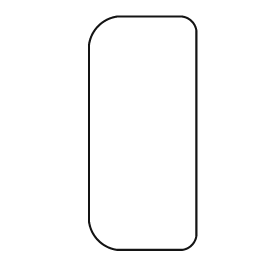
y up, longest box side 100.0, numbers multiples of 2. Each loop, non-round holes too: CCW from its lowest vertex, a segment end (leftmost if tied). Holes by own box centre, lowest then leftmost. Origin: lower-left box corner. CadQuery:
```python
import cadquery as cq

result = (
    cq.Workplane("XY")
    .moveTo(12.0, 0.0)
    .lineTo(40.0, 0.0)
    .threePointArc((44.0, 2.0), (46.0, 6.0))
    .lineTo(46.0, 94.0)
    .threePointArc((44.0, 98.0), (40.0, 100.0))
    .lineTo(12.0, 100.0)
    .threePointArc((4.0, 96.0), (0.0, 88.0))
    .lineTo(0.0, 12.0)
    .threePointArc((4.0, 4.0), (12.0, 0.0))
    .close()
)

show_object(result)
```